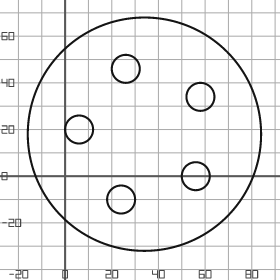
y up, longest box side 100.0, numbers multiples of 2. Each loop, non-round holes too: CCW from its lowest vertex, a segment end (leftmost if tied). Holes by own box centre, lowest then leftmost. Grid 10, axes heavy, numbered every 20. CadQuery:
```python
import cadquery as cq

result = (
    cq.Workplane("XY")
    .moveTo(34.0, 18.0)
    .circle(50.0)
    .moveTo(24.0, -10.0)
    .circle(6.0)
    .moveTo(56.0, 0.0)
    .circle(6.0)
    .moveTo(6.0, 20.0)
    .circle(6.0)
    .moveTo(58.0, 34.0)
    .circle(6.0)
    .moveTo(26.0, 46.0)
    .circle(6.0)
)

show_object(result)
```